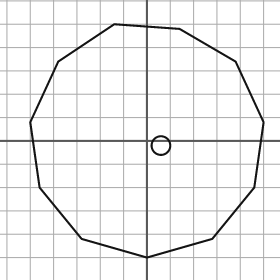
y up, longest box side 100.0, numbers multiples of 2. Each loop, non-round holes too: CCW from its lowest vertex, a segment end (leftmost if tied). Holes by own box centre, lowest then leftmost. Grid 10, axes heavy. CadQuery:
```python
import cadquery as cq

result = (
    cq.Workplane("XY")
    .moveTo(0.0, -50.0)
    .lineTo(28.0, -42.0)
    .lineTo(46.0, -20.0)
    .lineTo(50.0, 8.0)
    .lineTo(38.0, 34.0)
    .lineTo(14.0, 48.0)
    .lineTo(-14.0, 50.0)
    .lineTo(-38.0, 34.0)
    .lineTo(-50.0, 8.0)
    .lineTo(-46.0, -20.0)
    .lineTo(-28.0, -42.0)
    .close()
    .moveTo(6.0, -2.0)
    .circle(4.0)
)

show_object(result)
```